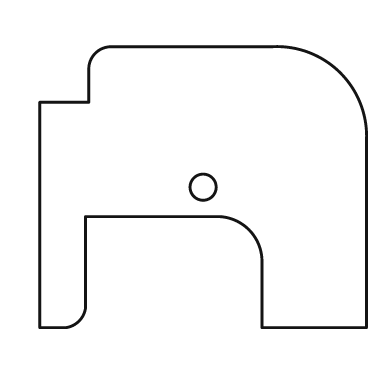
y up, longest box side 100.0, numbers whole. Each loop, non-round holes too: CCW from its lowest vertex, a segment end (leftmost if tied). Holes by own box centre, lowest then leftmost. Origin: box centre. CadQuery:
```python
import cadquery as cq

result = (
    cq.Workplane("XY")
    .moveTo(-50.0, -43.0)
    .lineTo(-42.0, -43.0)
    .threePointArc((-38.0, -41.0), (-36.0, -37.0))
    .lineTo(-36.0, -9.0)
    .lineTo(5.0, -9.0)
    .threePointArc((14.0, -13.0), (18.0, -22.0))
    .lineTo(18.0, -43.0)
    .lineTo(50.0, -43.0)
    .lineTo(50.0, 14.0)
    .threePointArc((42.0, 35.0), (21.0, 43.0))
    .lineTo(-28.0, 43.0)
    .threePointArc((-33.0, 41.0), (-35.0, 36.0))
    .lineTo(-35.0, 26.0)
    .lineTo(-50.0, 26.0)
    .close()
    .moveTo(0.0, 0.0)
    .circle(4.0)
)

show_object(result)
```